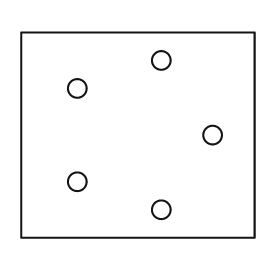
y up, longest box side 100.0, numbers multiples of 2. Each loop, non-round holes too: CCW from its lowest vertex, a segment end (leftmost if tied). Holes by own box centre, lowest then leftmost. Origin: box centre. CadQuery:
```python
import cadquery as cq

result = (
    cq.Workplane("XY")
    .moveTo(-50.0, -44.0)
    .lineTo(50.0, -44.0)
    .lineTo(50.0, 44.0)
    .lineTo(-50.0, 44.0)
    .close()
    .moveTo(10.0, -32.0)
    .circle(4.0)
    .moveTo(-26.0, -20.0)
    .circle(4.0)
    .moveTo(32.0, 0.0)
    .circle(4.0)
    .moveTo(-26.0, 20.0)
    .circle(4.0)
    .moveTo(10.0, 32.0)
    .circle(4.0)
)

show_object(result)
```